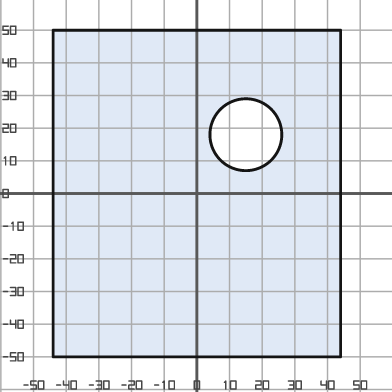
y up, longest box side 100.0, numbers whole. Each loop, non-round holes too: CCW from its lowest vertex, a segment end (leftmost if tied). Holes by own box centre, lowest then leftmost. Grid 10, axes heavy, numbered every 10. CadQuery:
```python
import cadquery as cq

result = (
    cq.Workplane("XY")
    .moveTo(-44.0, -50.0)
    .lineTo(44.0, -50.0)
    .lineTo(44.0, 50.0)
    .lineTo(-44.0, 50.0)
    .close()
    .moveTo(15.0, 18.0)
    .circle(11.0)
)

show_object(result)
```